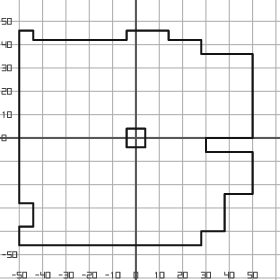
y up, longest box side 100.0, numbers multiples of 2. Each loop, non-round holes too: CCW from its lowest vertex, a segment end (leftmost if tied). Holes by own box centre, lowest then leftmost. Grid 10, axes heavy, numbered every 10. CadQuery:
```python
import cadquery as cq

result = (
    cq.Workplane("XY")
    .moveTo(-50.0, -46.0)
    .lineTo(28.0, -46.0)
    .lineTo(28.0, -40.0)
    .lineTo(38.0, -40.0)
    .lineTo(38.0, -24.0)
    .lineTo(50.0, -24.0)
    .lineTo(50.0, -6.0)
    .lineTo(30.0, -6.0)
    .lineTo(30.0, 0.0)
    .lineTo(50.0, 0.0)
    .lineTo(50.0, 36.0)
    .lineTo(28.0, 36.0)
    .lineTo(28.0, 42.0)
    .lineTo(14.0, 42.0)
    .lineTo(14.0, 46.0)
    .lineTo(-4.0, 46.0)
    .lineTo(-4.0, 42.0)
    .lineTo(-44.0, 42.0)
    .lineTo(-44.0, 46.0)
    .lineTo(-50.0, 46.0)
    .lineTo(-50.0, -28.0)
    .lineTo(-44.0, -28.0)
    .lineTo(-44.0, -38.0)
    .lineTo(-50.0, -38.0)
    .close()
    .moveTo(-4.0, -4.0)
    .lineTo(4.0, -4.0)
    .lineTo(4.0, 4.0)
    .lineTo(-4.0, 4.0)
    .close()
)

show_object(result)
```